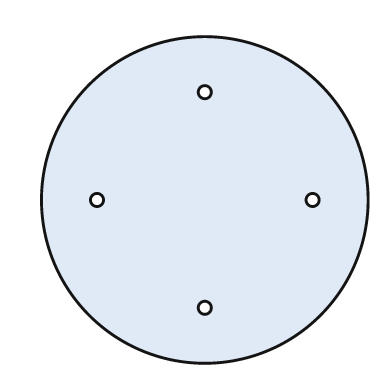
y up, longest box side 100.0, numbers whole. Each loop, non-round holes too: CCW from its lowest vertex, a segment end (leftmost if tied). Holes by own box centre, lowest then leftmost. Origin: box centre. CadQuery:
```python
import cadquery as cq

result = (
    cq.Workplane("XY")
    .moveTo(0.0, 0.0)
    .circle(50.0)
    .moveTo(0.0, -33.0)
    .circle(2.0)
    .moveTo(-33.0, 0.0)
    .circle(2.0)
    .moveTo(33.0, 0.0)
    .circle(2.0)
    .moveTo(0.0, 33.0)
    .circle(2.0)
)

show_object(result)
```